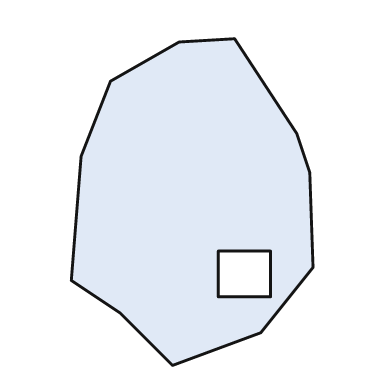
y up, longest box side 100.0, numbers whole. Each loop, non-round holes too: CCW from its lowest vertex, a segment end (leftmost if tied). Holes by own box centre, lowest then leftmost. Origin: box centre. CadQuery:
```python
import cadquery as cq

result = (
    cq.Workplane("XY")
    .moveTo(-6.0, -50.0)
    .lineTo(21.0, -40.0)
    .lineTo(37.0, -20.0)
    .lineTo(36.0, 9.0)
    .lineTo(32.0, 21.0)
    .lineTo(13.0, 50.0)
    .lineTo(-4.0, 49.0)
    .lineTo(-25.0, 37.0)
    .lineTo(-34.0, 14.0)
    .lineTo(-37.0, -24.0)
    .lineTo(-22.0, -34.0)
    .close()
    .moveTo(8.0, -29.0)
    .lineTo(24.0, -29.0)
    .lineTo(24.0, -15.0)
    .lineTo(8.0, -15.0)
    .close()
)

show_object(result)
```